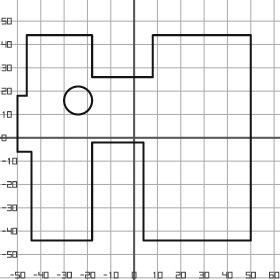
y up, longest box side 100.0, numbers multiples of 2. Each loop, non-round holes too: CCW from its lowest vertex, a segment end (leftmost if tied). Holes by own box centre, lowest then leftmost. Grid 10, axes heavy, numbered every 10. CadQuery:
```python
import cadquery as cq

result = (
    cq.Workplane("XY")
    .moveTo(-44.0, -44.0)
    .lineTo(-18.0, -44.0)
    .lineTo(-18.0, -2.0)
    .lineTo(4.0, -2.0)
    .lineTo(4.0, -44.0)
    .lineTo(50.0, -44.0)
    .lineTo(50.0, 44.0)
    .lineTo(8.0, 44.0)
    .lineTo(8.0, 26.0)
    .lineTo(-18.0, 26.0)
    .lineTo(-18.0, 44.0)
    .lineTo(-46.0, 44.0)
    .lineTo(-46.0, 18.0)
    .lineTo(-50.0, 18.0)
    .lineTo(-50.0, -6.0)
    .lineTo(-44.0, -6.0)
    .close()
    .moveTo(-24.0, 16.0)
    .circle(6.0)
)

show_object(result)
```